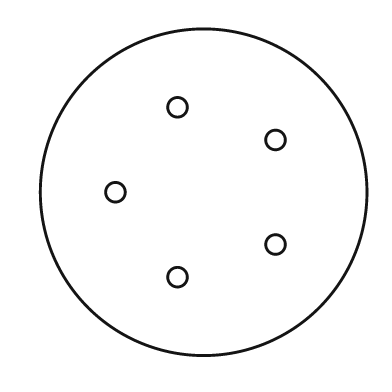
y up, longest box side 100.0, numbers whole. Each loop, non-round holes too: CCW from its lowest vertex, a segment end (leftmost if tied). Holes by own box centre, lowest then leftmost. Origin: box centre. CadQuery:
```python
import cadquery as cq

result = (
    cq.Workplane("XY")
    .moveTo(0.0, 0.0)
    .circle(50.0)
    .moveTo(-8.0, -26.0)
    .circle(3.0)
    .moveTo(22.0, -16.0)
    .circle(3.0)
    .moveTo(-27.0, 0.0)
    .circle(3.0)
    .moveTo(22.0, 16.0)
    .circle(3.0)
    .moveTo(-8.0, 26.0)
    .circle(3.0)
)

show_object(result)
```